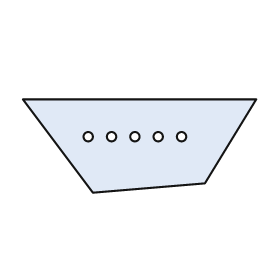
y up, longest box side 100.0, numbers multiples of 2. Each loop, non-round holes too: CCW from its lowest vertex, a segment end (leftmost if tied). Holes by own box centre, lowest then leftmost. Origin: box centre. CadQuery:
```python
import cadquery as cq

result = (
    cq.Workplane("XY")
    .moveTo(-20.0, -20.0)
    .lineTo(28.0, -16.0)
    .lineTo(50.0, 20.0)
    .lineTo(-50.0, 20.0)
    .close()
    .moveTo(-22.0, 4.0)
    .circle(2.0)
    .moveTo(-12.0, 4.0)
    .circle(2.0)
    .moveTo(-2.0, 4.0)
    .circle(2.0)
    .moveTo(8.0, 4.0)
    .circle(2.0)
    .moveTo(18.0, 4.0)
    .circle(2.0)
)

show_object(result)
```